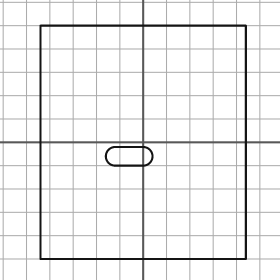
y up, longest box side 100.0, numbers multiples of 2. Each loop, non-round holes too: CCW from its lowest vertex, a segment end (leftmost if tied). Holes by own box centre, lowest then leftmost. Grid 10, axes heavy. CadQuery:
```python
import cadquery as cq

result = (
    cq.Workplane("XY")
    .moveTo(-44.0, -50.0)
    .lineTo(44.0, -50.0)
    .lineTo(44.0, 50.0)
    .lineTo(-44.0, 50.0)
    .close()
    .moveTo(-12.0, -10.0)
    .lineTo(0.0, -10.0)
    .threePointArc((4.0, -6.0), (0.0, -2.0))
    .lineTo(-12.0, -2.0)
    .threePointArc((-16.0, -6.0), (-12.0, -10.0))
    .close()
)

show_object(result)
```